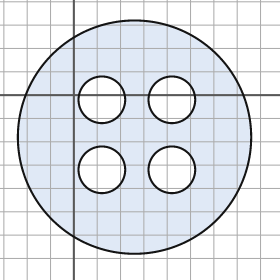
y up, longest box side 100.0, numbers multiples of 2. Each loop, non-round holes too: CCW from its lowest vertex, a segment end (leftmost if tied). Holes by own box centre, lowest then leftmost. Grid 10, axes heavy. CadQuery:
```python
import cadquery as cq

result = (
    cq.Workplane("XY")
    .moveTo(26.0, -18.0)
    .circle(50.0)
    .moveTo(12.0, -32.0)
    .circle(10.0)
    .moveTo(42.0, -32.0)
    .circle(10.0)
    .moveTo(12.0, -2.0)
    .circle(10.0)
    .moveTo(42.0, -2.0)
    .circle(10.0)
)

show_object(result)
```